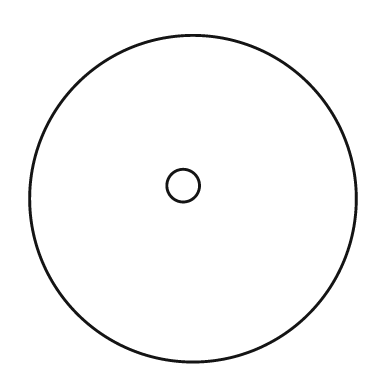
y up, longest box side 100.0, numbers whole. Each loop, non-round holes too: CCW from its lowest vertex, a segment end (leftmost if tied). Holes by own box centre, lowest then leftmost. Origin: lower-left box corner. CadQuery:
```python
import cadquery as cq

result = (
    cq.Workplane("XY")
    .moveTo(50.0, 50.0)
    .circle(50.0)
    .moveTo(47.0, 54.0)
    .circle(5.0)
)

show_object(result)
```